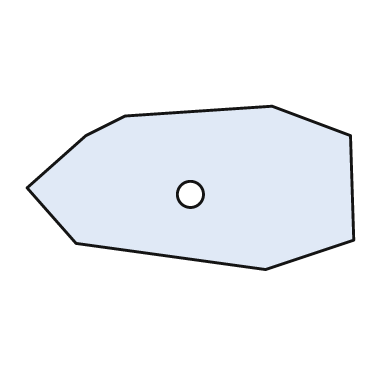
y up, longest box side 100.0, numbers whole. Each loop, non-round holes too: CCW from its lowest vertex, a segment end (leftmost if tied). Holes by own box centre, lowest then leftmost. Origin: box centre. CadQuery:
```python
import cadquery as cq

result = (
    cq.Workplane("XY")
    .moveTo(23.0, -25.0)
    .lineTo(50.0, -16.0)
    .lineTo(49.0, 16.0)
    .lineTo(25.0, 25.0)
    .lineTo(-20.0, 22.0)
    .lineTo(-32.0, 16.0)
    .lineTo(-50.0, 0.0)
    .lineTo(-35.0, -17.0)
    .close()
    .moveTo(0.0, -2.0)
    .circle(4.0)
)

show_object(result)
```